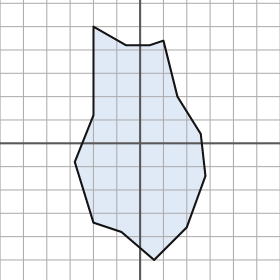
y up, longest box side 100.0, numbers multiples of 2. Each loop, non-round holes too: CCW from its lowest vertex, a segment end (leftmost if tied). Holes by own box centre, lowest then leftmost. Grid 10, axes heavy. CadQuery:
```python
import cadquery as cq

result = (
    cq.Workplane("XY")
    .moveTo(6.0, -50.0)
    .lineTo(20.0, -36.0)
    .lineTo(28.0, -14.0)
    .lineTo(26.0, 4.0)
    .lineTo(16.0, 20.0)
    .lineTo(10.0, 44.0)
    .lineTo(4.0, 42.0)
    .lineTo(-6.0, 42.0)
    .lineTo(-20.0, 50.0)
    .lineTo(-20.0, 12.0)
    .lineTo(-28.0, -8.0)
    .lineTo(-20.0, -34.0)
    .lineTo(-8.0, -38.0)
    .close()
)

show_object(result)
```